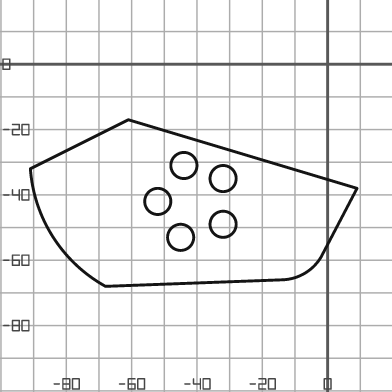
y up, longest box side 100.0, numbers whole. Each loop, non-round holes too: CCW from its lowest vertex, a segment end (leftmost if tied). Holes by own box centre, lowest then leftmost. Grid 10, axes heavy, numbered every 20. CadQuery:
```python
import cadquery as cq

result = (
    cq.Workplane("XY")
    .moveTo(-68.0, -68.0)
    .lineTo(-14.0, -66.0)
    .threePointArc((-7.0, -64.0), (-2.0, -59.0))
    .lineTo(9.0, -38.0)
    .lineTo(-61.0, -17.0)
    .lineTo(-91.0, -32.0)
    .threePointArc((-84.0, -53.0), (-68.0, -68.0))
    .close()
    .moveTo(-45.0, -53.0)
    .circle(4.0)
    .moveTo(-32.0, -49.0)
    .circle(4.0)
    .moveTo(-52.0, -42.0)
    .circle(4.0)
    .moveTo(-32.0, -35.0)
    .circle(4.0)
    .moveTo(-44.0, -31.0)
    .circle(4.0)
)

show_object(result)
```